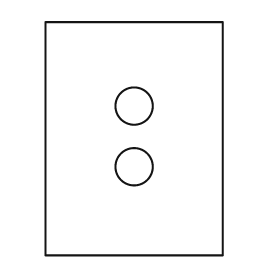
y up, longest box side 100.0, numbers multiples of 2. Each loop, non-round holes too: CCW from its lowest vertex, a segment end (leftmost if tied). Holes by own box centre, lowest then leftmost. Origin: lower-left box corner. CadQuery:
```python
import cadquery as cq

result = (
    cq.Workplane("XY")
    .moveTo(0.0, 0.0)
    .lineTo(76.0, 0.0)
    .lineTo(76.0, 100.0)
    .lineTo(0.0, 100.0)
    .close()
    .moveTo(38.0, 38.0)
    .circle(8.0)
    .moveTo(38.0, 64.0)
    .circle(8.0)
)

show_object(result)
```